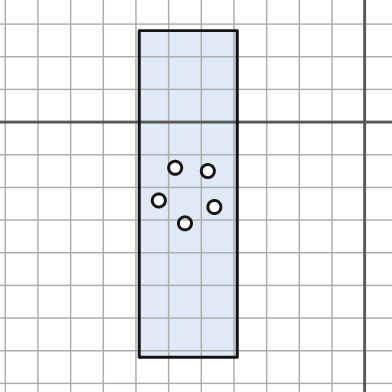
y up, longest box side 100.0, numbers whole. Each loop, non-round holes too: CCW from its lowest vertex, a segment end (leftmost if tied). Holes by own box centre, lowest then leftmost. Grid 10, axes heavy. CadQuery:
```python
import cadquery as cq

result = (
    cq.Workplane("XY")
    .moveTo(-69.0, -72.0)
    .lineTo(-39.0, -72.0)
    .lineTo(-39.0, 28.0)
    .lineTo(-69.0, 28.0)
    .close()
    .moveTo(-55.0, -31.0)
    .circle(2.0)
    .moveTo(-46.0, -26.0)
    .circle(2.0)
    .moveTo(-63.0, -24.0)
    .circle(2.0)
    .moveTo(-48.0, -15.0)
    .circle(2.0)
    .moveTo(-58.0, -14.0)
    .circle(2.0)
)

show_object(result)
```